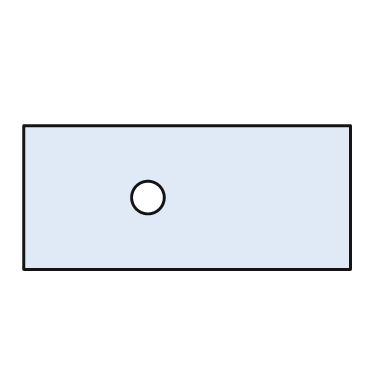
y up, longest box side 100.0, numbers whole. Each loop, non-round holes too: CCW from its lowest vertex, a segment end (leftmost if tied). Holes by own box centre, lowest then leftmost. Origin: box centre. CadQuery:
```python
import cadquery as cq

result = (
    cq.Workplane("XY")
    .moveTo(-50.0, -22.0)
    .lineTo(50.0, -22.0)
    .lineTo(50.0, 22.0)
    .lineTo(-50.0, 22.0)
    .close()
    .moveTo(-12.0, 0.0)
    .circle(5.0)
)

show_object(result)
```